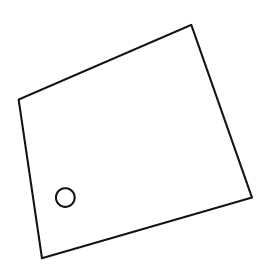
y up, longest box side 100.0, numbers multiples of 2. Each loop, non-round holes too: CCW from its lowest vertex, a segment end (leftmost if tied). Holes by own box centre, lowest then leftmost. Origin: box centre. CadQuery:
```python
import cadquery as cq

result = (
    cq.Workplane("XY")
    .moveTo(-40.0, -50.0)
    .lineTo(50.0, -24.0)
    .lineTo(24.0, 50.0)
    .lineTo(-50.0, 18.0)
    .close()
    .moveTo(-30.0, -24.0)
    .circle(4.0)
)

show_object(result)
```